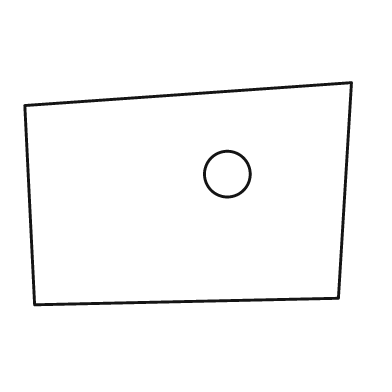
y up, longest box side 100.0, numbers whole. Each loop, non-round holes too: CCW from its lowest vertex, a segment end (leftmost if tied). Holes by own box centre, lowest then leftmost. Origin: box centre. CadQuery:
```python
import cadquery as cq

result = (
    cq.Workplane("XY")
    .moveTo(-47.0, -34.0)
    .lineTo(46.0, -32.0)
    .lineTo(50.0, 34.0)
    .lineTo(-50.0, 27.0)
    .close()
    .moveTo(12.0, 6.0)
    .circle(7.0)
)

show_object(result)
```